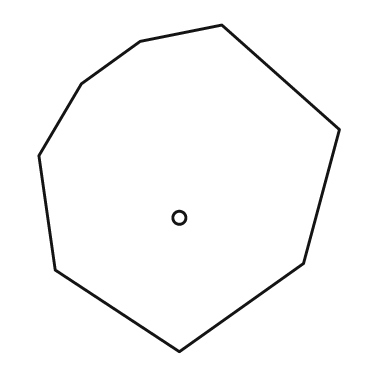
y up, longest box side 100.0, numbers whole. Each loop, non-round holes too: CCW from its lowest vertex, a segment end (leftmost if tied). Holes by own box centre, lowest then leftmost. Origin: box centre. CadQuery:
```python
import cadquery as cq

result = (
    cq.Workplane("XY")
    .moveTo(-3.0, -50.0)
    .lineTo(35.0, -23.0)
    .lineTo(46.0, 18.0)
    .lineTo(10.0, 50.0)
    .lineTo(-15.0, 45.0)
    .lineTo(-33.0, 32.0)
    .lineTo(-46.0, 10.0)
    .lineTo(-41.0, -25.0)
    .close()
    .moveTo(-3.0, -9.0)
    .circle(2.0)
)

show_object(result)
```